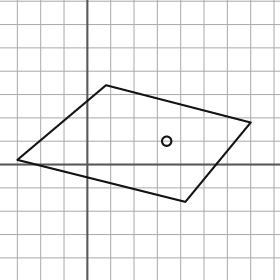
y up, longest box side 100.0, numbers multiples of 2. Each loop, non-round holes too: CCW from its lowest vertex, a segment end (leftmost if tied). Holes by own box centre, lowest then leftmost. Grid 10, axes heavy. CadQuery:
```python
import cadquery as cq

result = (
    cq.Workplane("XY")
    .moveTo(42.0, -16.0)
    .lineTo(70.0, 18.0)
    .lineTo(8.0, 34.0)
    .lineTo(-30.0, 2.0)
    .close()
    .moveTo(34.0, 10.0)
    .circle(2.0)
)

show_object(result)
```